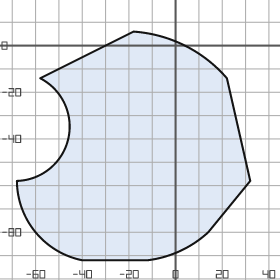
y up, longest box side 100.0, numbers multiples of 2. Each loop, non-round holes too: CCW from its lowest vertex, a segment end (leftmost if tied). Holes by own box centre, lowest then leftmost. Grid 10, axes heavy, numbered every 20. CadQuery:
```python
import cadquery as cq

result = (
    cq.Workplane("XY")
    .moveTo(-40.0, -92.0)
    .lineTo(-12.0, -92.0)
    .threePointArc((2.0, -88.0), (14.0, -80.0))
    .lineTo(32.0, -58.0)
    .lineTo(22.0, -14.0)
    .threePointArc((4.0, 0.0), (-18.0, 6.0))
    .lineTo(-58.0, -14.0)
    .threePointArc((-46.0, -40.0), (-68.0, -58.0))
    .threePointArc((-60.0, -80.0), (-40.0, -92.0))
    .close()
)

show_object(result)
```